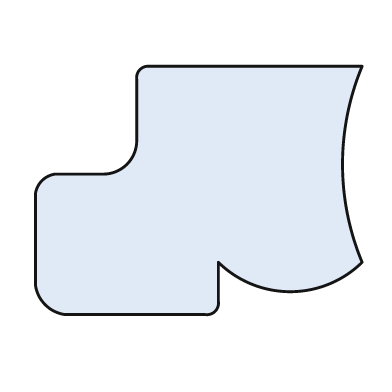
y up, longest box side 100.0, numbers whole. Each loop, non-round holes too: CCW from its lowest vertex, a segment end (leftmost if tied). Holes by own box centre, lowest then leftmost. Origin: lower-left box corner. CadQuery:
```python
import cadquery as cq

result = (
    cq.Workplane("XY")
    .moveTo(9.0, 0.0)
    .lineTo(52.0, 0.0)
    .threePointArc((55.0, 1.0), (56.0, 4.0))
    .lineTo(56.0, 16.0)
    .threePointArc((78.0, 7.0), (100.0, 16.0))
    .threePointArc((94.0, 46.0), (100.0, 76.0))
    .lineTo(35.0, 76.0)
    .threePointArc((32.0, 75.0), (31.0, 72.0))
    .lineTo(31.0, 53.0)
    .threePointArc((28.0, 46.0), (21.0, 43.0))
    .lineTo(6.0, 43.0)
    .threePointArc((2.0, 41.0), (0.0, 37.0))
    .lineTo(0.0, 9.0)
    .threePointArc((3.0, 3.0), (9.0, 0.0))
    .close()
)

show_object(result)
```